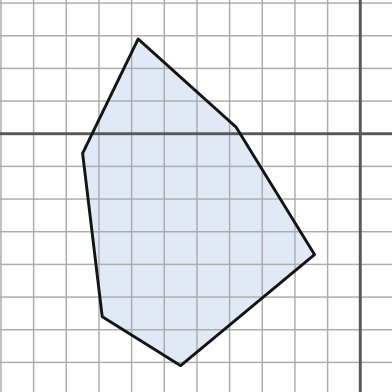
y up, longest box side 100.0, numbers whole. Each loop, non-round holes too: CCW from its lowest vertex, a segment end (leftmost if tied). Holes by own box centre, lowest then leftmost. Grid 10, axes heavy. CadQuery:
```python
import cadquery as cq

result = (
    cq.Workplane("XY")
    .moveTo(-55.0, -71.0)
    .lineTo(-14.0, -37.0)
    .lineTo(-38.0, 2.0)
    .lineTo(-68.0, 29.0)
    .lineTo(-85.0, -6.0)
    .lineTo(-79.0, -56.0)
    .close()
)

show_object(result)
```